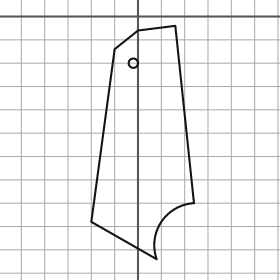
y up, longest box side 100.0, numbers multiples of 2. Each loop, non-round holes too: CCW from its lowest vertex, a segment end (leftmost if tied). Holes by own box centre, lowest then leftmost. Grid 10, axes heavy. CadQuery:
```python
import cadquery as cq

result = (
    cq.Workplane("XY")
    .moveTo(8.0, -104.0)
    .threePointArc((10.0, -88.0), (24.0, -80.0))
    .lineTo(16.0, -4.0)
    .lineTo(0.0, -6.0)
    .lineTo(-10.0, -14.0)
    .lineTo(-20.0, -88.0)
    .close()
    .moveTo(-2.0, -20.0)
    .circle(2.0)
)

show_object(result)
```